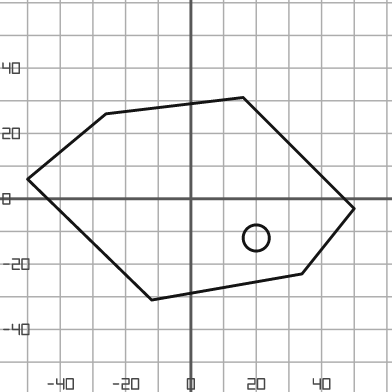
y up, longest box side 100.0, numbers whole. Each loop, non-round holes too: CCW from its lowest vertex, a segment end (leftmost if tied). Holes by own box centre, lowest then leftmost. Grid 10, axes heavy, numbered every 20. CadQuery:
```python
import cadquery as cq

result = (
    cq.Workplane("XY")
    .moveTo(-12.0, -31.0)
    .lineTo(34.0, -23.0)
    .lineTo(50.0, -3.0)
    .lineTo(16.0, 31.0)
    .lineTo(-26.0, 26.0)
    .lineTo(-50.0, 6.0)
    .close()
    .moveTo(20.0, -12.0)
    .circle(4.0)
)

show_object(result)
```